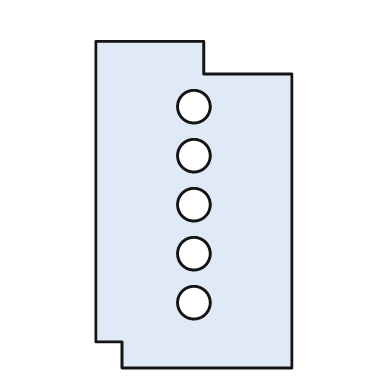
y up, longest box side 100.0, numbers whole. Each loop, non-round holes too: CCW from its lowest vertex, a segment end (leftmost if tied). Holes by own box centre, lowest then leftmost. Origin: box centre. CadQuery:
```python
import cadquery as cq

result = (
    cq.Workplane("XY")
    .moveTo(-22.0, -50.0)
    .lineTo(30.0, -50.0)
    .lineTo(30.0, 40.0)
    .lineTo(3.0, 40.0)
    .lineTo(3.0, 50.0)
    .lineTo(-30.0, 50.0)
    .lineTo(-30.0, -42.0)
    .lineTo(-22.0, -42.0)
    .close()
    .moveTo(0.0, -30.0)
    .circle(5.0)
    .moveTo(0.0, -15.0)
    .circle(5.0)
    .moveTo(0.0, 0.0)
    .circle(5.0)
    .moveTo(0.0, 15.0)
    .circle(5.0)
    .moveTo(0.0, 30.0)
    .circle(5.0)
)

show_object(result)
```